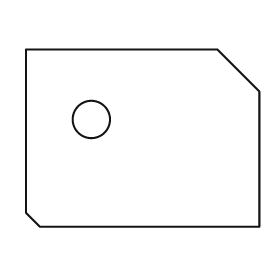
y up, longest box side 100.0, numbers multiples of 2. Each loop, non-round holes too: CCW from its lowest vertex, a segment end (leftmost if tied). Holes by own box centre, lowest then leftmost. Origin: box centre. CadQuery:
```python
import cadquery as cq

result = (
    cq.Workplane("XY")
    .moveTo(-44.0, -38.0)
    .lineTo(50.0, -38.0)
    .lineTo(50.0, 20.0)
    .lineTo(32.0, 38.0)
    .lineTo(-50.0, 38.0)
    .lineTo(-50.0, -32.0)
    .close()
    .moveTo(-22.0, 8.0)
    .circle(8.0)
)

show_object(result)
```